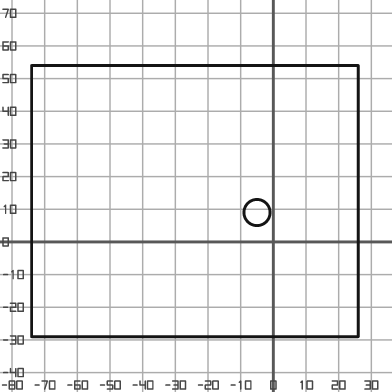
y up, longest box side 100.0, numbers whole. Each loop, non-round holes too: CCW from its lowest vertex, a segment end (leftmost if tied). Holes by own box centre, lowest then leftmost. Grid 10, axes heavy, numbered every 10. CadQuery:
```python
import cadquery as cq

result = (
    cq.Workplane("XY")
    .moveTo(-74.0, -29.0)
    .lineTo(26.0, -29.0)
    .lineTo(26.0, 54.0)
    .lineTo(-74.0, 54.0)
    .close()
    .moveTo(-5.0, 9.0)
    .circle(4.0)
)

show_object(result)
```